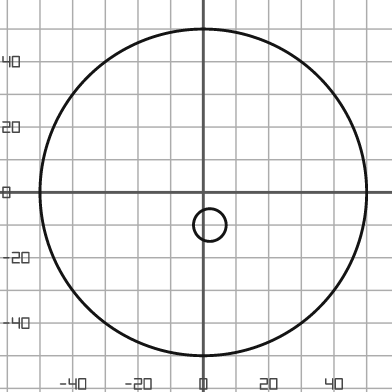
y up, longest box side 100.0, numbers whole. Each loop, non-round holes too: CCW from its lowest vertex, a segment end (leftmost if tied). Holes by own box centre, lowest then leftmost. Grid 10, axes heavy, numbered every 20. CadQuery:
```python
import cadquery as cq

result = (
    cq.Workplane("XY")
    .moveTo(0.0, 0.0)
    .circle(50.0)
    .moveTo(2.0, -10.0)
    .circle(5.0)
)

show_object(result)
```